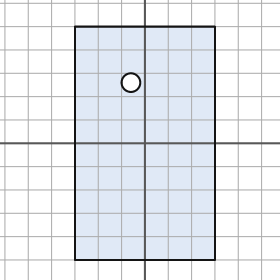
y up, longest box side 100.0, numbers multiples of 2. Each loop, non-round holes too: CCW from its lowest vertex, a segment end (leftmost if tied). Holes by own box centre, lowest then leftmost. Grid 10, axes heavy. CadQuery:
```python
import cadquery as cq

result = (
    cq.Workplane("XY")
    .moveTo(-30.0, -50.0)
    .lineTo(30.0, -50.0)
    .lineTo(30.0, 50.0)
    .lineTo(-30.0, 50.0)
    .close()
    .moveTo(-6.0, 26.0)
    .circle(4.0)
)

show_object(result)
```